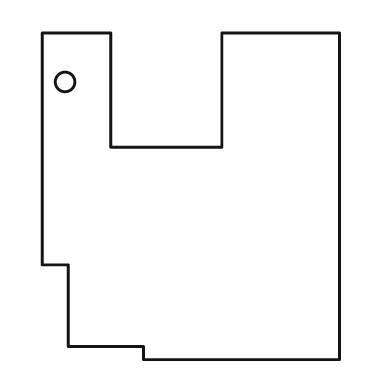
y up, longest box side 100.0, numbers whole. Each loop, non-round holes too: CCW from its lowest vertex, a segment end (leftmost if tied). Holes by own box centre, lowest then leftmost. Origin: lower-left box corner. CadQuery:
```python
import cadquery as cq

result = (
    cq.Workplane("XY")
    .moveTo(31.0, 0.0)
    .lineTo(91.0, 0.0)
    .lineTo(91.0, 100.0)
    .lineTo(55.0, 100.0)
    .lineTo(55.0, 65.0)
    .lineTo(21.0, 65.0)
    .lineTo(21.0, 100.0)
    .lineTo(0.0, 100.0)
    .lineTo(0.0, 29.0)
    .lineTo(8.0, 29.0)
    .lineTo(8.0, 4.0)
    .lineTo(31.0, 4.0)
    .close()
    .moveTo(7.0, 85.0)
    .circle(3.0)
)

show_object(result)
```